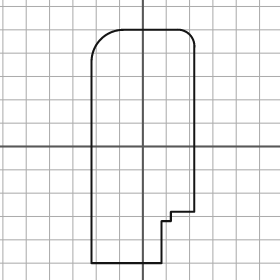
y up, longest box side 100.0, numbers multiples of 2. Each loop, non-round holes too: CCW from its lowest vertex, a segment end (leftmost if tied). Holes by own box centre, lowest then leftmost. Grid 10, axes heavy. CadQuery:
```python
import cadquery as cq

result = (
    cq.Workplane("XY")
    .moveTo(-22.0, -50.0)
    .lineTo(8.0, -50.0)
    .lineTo(8.0, -32.0)
    .lineTo(12.0, -32.0)
    .lineTo(12.0, -28.0)
    .lineTo(22.0, -28.0)
    .lineTo(22.0, 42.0)
    .threePointArc((20.0, 48.0), (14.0, 50.0))
    .lineTo(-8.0, 50.0)
    .threePointArc((-18.0, 46.0), (-22.0, 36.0))
    .close()
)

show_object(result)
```